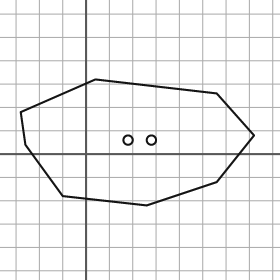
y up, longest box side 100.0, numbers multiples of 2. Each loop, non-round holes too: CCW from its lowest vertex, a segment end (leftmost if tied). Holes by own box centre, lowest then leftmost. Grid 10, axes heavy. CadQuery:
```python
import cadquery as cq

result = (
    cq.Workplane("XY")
    .moveTo(26.0, -22.0)
    .lineTo(56.0, -12.0)
    .lineTo(72.0, 8.0)
    .lineTo(56.0, 26.0)
    .lineTo(4.0, 32.0)
    .lineTo(-28.0, 18.0)
    .lineTo(-26.0, 4.0)
    .lineTo(-10.0, -18.0)
    .close()
    .moveTo(18.0, 6.0)
    .circle(2.0)
    .moveTo(28.0, 6.0)
    .circle(2.0)
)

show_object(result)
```